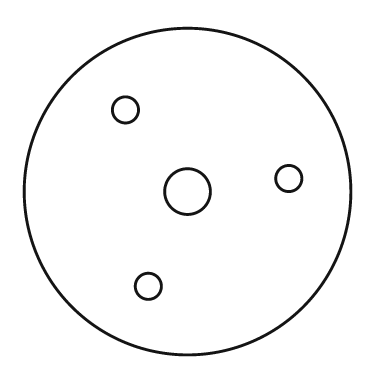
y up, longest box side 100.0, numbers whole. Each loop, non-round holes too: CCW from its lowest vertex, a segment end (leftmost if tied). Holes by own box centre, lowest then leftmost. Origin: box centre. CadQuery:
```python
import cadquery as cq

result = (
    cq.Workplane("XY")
    .moveTo(0.0, 0.0)
    .circle(50.0)
    .moveTo(-12.0, -29.0)
    .circle(4.0)
    .moveTo(0.0, 0.0)
    .circle(7.0)
    .moveTo(31.0, 4.0)
    .circle(4.0)
    .moveTo(-19.0, 25.0)
    .circle(4.0)
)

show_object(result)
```